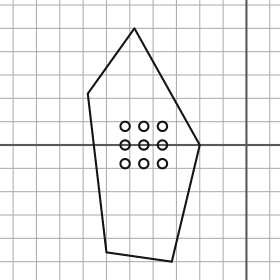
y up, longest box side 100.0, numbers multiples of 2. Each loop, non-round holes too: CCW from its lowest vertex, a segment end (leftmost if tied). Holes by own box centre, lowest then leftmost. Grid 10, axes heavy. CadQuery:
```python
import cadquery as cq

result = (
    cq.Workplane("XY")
    .moveTo(-32.0, -50.0)
    .lineTo(-20.0, 0.0)
    .lineTo(-48.0, 50.0)
    .lineTo(-68.0, 22.0)
    .lineTo(-60.0, -46.0)
    .close()
    .moveTo(-52.0, -8.0)
    .circle(2.0)
    .moveTo(-44.0, -8.0)
    .circle(2.0)
    .moveTo(-36.0, -8.0)
    .circle(2.0)
    .moveTo(-52.0, 0.0)
    .circle(2.0)
    .moveTo(-44.0, 0.0)
    .circle(2.0)
    .moveTo(-36.0, 0.0)
    .circle(2.0)
    .moveTo(-52.0, 8.0)
    .circle(2.0)
    .moveTo(-44.0, 8.0)
    .circle(2.0)
    .moveTo(-36.0, 8.0)
    .circle(2.0)
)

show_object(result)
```